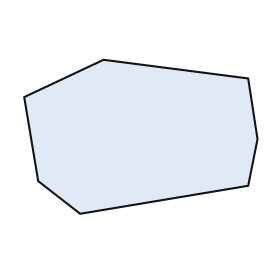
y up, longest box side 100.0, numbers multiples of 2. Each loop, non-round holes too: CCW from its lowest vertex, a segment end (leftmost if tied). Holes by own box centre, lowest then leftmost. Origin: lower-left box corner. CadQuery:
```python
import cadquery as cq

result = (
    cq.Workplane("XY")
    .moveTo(24.0, 0.0)
    .lineTo(96.0, 12.0)
    .lineTo(100.0, 32.0)
    .lineTo(96.0, 58.0)
    .lineTo(34.0, 66.0)
    .lineTo(0.0, 50.0)
    .lineTo(6.0, 14.0)
    .close()
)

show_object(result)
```